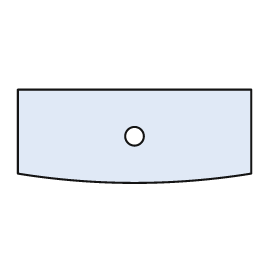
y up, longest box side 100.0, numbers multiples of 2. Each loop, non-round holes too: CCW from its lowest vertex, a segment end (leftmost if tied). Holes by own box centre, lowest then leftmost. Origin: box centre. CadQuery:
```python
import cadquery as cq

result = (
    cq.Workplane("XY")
    .moveTo(-50.0, -16.0)
    .threePointArc((0.0, -20.0), (50.0, -16.0))
    .lineTo(50.0, 20.0)
    .lineTo(-50.0, 20.0)
    .close()
    .moveTo(0.0, 0.0)
    .circle(4.0)
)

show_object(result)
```